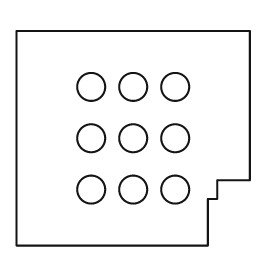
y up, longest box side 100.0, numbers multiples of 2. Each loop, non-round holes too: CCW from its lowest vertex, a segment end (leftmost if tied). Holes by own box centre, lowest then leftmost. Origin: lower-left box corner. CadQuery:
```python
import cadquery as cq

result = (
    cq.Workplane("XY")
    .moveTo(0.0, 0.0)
    .lineTo(82.0, 0.0)
    .lineTo(82.0, 20.0)
    .lineTo(86.0, 20.0)
    .lineTo(86.0, 28.0)
    .lineTo(100.0, 28.0)
    .lineTo(100.0, 92.0)
    .lineTo(0.0, 92.0)
    .close()
    .moveTo(32.0, 24.0)
    .circle(6.0)
    .moveTo(50.0, 24.0)
    .circle(6.0)
    .moveTo(68.0, 24.0)
    .circle(6.0)
    .moveTo(32.0, 46.0)
    .circle(6.0)
    .moveTo(50.0, 46.0)
    .circle(6.0)
    .moveTo(68.0, 46.0)
    .circle(6.0)
    .moveTo(32.0, 68.0)
    .circle(6.0)
    .moveTo(50.0, 68.0)
    .circle(6.0)
    .moveTo(68.0, 68.0)
    .circle(6.0)
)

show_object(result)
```